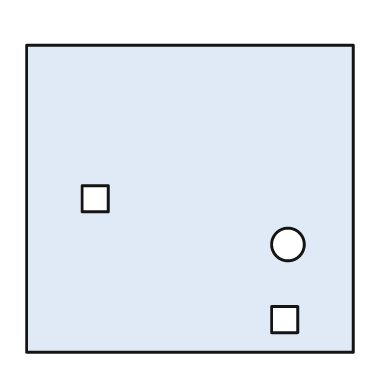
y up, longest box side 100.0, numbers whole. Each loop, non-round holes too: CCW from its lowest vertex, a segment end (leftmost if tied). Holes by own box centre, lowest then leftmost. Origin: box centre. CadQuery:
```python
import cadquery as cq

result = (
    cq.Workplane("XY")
    .moveTo(-50.0, -47.0)
    .lineTo(50.0, -47.0)
    .lineTo(50.0, 47.0)
    .lineTo(-50.0, 47.0)
    .close()
    .moveTo(25.0, -41.0)
    .lineTo(33.0, -41.0)
    .lineTo(33.0, -33.0)
    .lineTo(25.0, -33.0)
    .close()
    .moveTo(30.0, -14.0)
    .circle(5.0)
    .moveTo(-33.0, -4.0)
    .lineTo(-25.0, -4.0)
    .lineTo(-25.0, 4.0)
    .lineTo(-33.0, 4.0)
    .close()
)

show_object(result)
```